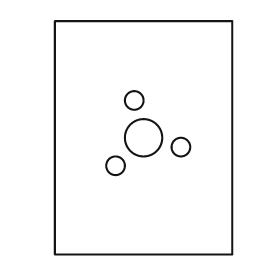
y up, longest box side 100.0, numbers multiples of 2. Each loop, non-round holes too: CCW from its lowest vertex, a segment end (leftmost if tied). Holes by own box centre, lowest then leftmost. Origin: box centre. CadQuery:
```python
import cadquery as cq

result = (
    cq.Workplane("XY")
    .moveTo(-38.0, -50.0)
    .lineTo(38.0, -50.0)
    .lineTo(38.0, 50.0)
    .lineTo(-38.0, 50.0)
    .close()
    .moveTo(-12.0, -12.0)
    .circle(4.0)
    .moveTo(16.0, -4.0)
    .circle(4.0)
    .moveTo(0.0, 0.0)
    .circle(8.0)
    .moveTo(-4.0, 16.0)
    .circle(4.0)
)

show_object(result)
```